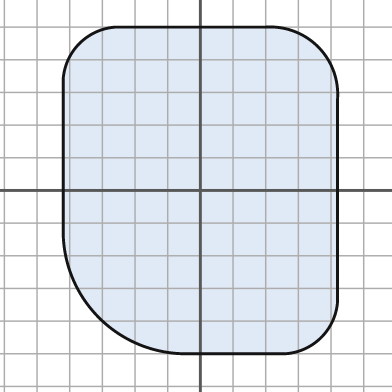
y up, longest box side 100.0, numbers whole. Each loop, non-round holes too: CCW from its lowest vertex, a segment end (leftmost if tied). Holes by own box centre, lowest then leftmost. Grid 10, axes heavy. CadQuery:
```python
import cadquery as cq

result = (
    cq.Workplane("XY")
    .moveTo(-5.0, -50.0)
    .lineTo(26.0, -50.0)
    .threePointArc((37.0, -45.0), (42.0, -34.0))
    .lineTo(42.0, 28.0)
    .threePointArc((36.0, 44.0), (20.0, 50.0))
    .lineTo(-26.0, 50.0)
    .threePointArc((-37.0, 45.0), (-42.0, 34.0))
    .lineTo(-42.0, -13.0)
    .threePointArc((-31.0, -39.0), (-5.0, -50.0))
    .close()
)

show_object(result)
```